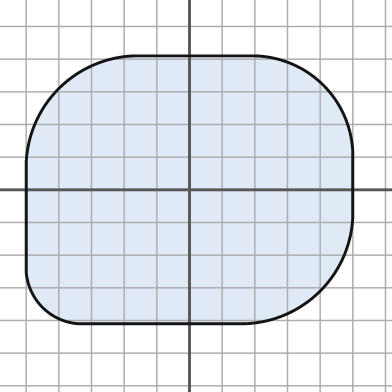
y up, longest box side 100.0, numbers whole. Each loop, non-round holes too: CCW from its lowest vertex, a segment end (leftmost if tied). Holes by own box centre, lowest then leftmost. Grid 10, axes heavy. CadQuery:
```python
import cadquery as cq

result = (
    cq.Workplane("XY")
    .moveTo(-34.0, -41.0)
    .lineTo(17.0, -41.0)
    .threePointArc((40.0, -31.0), (50.0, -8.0))
    .lineTo(50.0, 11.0)
    .threePointArc((41.0, 32.0), (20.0, 41.0))
    .lineTo(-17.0, 41.0)
    .threePointArc((-40.0, 31.0), (-50.0, 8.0))
    .lineTo(-50.0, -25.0)
    .threePointArc((-45.0, -36.0), (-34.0, -41.0))
    .close()
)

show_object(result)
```